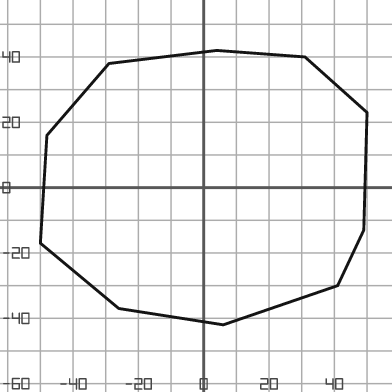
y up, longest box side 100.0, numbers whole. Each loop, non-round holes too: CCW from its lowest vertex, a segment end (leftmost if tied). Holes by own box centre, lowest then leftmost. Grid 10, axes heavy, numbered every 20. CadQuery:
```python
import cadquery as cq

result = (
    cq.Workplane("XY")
    .moveTo(6.0, -42.0)
    .lineTo(41.0, -30.0)
    .lineTo(49.0, -13.0)
    .lineTo(50.0, 23.0)
    .lineTo(31.0, 40.0)
    .lineTo(4.0, 42.0)
    .lineTo(-29.0, 38.0)
    .lineTo(-48.0, 16.0)
    .lineTo(-50.0, -17.0)
    .lineTo(-26.0, -37.0)
    .close()
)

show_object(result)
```